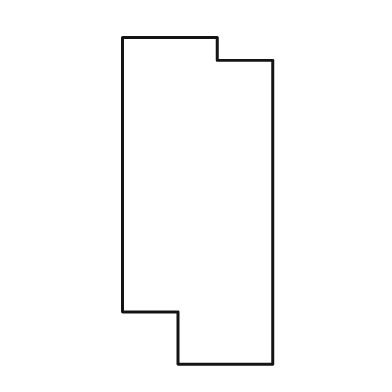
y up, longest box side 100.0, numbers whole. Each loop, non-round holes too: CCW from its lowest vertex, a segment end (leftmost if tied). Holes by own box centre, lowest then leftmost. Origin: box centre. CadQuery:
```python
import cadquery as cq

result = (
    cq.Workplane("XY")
    .moveTo(-6.0, -50.0)
    .lineTo(23.0, -50.0)
    .lineTo(23.0, 43.0)
    .lineTo(6.0, 43.0)
    .lineTo(6.0, 50.0)
    .lineTo(-23.0, 50.0)
    .lineTo(-23.0, -34.0)
    .lineTo(-6.0, -34.0)
    .close()
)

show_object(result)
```